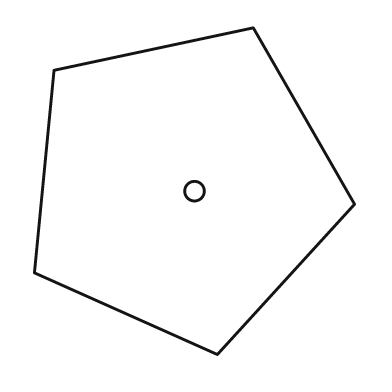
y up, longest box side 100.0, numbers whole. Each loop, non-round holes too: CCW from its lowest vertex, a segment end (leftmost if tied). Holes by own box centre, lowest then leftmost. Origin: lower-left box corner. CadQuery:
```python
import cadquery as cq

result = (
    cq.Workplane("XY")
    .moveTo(56.0, 0.0)
    .lineTo(98.0, 46.0)
    .lineTo(67.0, 100.0)
    .lineTo(6.0, 87.0)
    .lineTo(0.0, 25.0)
    .close()
    .moveTo(49.0, 50.0)
    .circle(3.0)
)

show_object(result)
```